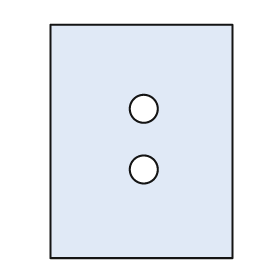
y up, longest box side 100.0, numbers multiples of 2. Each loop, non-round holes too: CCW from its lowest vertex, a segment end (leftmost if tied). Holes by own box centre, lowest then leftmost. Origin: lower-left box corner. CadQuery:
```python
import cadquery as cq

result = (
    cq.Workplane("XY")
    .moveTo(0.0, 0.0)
    .lineTo(78.0, 0.0)
    .lineTo(78.0, 100.0)
    .lineTo(0.0, 100.0)
    .close()
    .moveTo(40.0, 38.0)
    .circle(6.0)
    .moveTo(40.0, 64.0)
    .circle(6.0)
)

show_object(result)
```